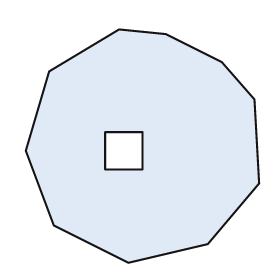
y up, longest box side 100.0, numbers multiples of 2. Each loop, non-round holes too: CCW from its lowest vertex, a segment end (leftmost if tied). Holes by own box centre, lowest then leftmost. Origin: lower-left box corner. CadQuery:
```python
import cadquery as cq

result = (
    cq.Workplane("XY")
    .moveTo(44.0, 0.0)
    .lineTo(78.0, 8.0)
    .lineTo(100.0, 34.0)
    .lineTo(98.0, 70.0)
    .lineTo(84.0, 86.0)
    .lineTo(60.0, 98.0)
    .lineTo(40.0, 100.0)
    .lineTo(10.0, 82.0)
    .lineTo(0.0, 48.0)
    .lineTo(12.0, 16.0)
    .close()
    .moveTo(34.0, 40.0)
    .lineTo(50.0, 40.0)
    .lineTo(50.0, 56.0)
    .lineTo(34.0, 56.0)
    .close()
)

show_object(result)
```